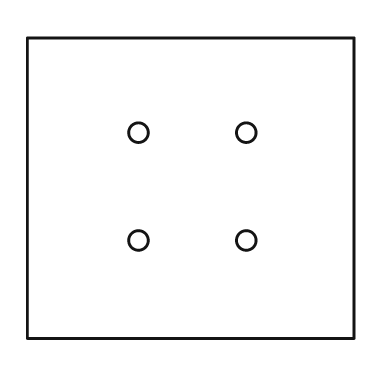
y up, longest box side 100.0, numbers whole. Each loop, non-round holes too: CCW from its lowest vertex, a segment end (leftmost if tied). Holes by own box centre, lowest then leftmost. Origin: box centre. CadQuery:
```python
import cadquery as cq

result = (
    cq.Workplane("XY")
    .moveTo(-50.0, -46.0)
    .lineTo(50.0, -46.0)
    .lineTo(50.0, 46.0)
    .lineTo(-50.0, 46.0)
    .close()
    .moveTo(-16.0, -16.0)
    .circle(3.0)
    .moveTo(17.0, -16.0)
    .circle(3.0)
    .moveTo(-16.0, 17.0)
    .circle(3.0)
    .moveTo(17.0, 17.0)
    .circle(3.0)
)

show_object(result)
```